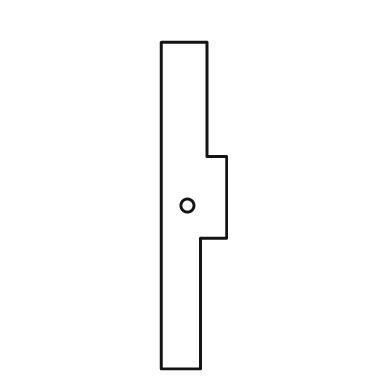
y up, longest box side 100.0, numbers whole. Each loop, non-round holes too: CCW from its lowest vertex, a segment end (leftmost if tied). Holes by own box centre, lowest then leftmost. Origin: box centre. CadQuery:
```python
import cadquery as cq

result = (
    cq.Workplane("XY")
    .moveTo(-10.0, -50.0)
    .lineTo(2.0, -50.0)
    .lineTo(2.0, -10.0)
    .lineTo(10.0, -10.0)
    .lineTo(10.0, 15.0)
    .lineTo(4.0, 15.0)
    .lineTo(4.0, 50.0)
    .lineTo(-10.0, 50.0)
    .close()
    .moveTo(-2.0, 0.0)
    .circle(2.0)
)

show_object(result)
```